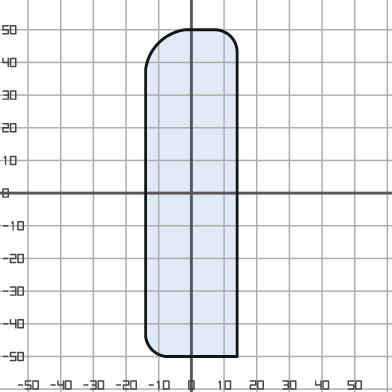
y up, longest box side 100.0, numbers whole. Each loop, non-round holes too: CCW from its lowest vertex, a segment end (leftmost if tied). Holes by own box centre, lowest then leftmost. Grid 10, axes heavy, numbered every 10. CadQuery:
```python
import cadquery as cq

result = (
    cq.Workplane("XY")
    .moveTo(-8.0, -50.0)
    .lineTo(14.0, -50.0)
    .lineTo(14.0, 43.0)
    .threePointArc((12.0, 48.0), (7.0, 50.0))
    .lineTo(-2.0, 50.0)
    .threePointArc((-10.0, 46.0), (-14.0, 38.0))
    .lineTo(-14.0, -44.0)
    .threePointArc((-12.0, -48.0), (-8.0, -50.0))
    .close()
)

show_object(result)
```